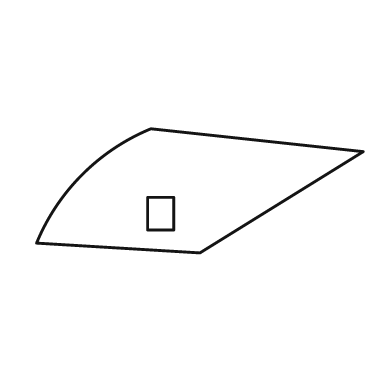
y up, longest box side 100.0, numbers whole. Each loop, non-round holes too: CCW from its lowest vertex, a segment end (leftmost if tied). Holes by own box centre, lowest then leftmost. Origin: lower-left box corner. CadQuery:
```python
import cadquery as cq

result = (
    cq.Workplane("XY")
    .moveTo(50.0, 0.0)
    .lineTo(100.0, 31.0)
    .lineTo(35.0, 38.0)
    .threePointArc((14.0, 24.0), (0.0, 3.0))
    .close()
    .moveTo(34.0, 7.0)
    .lineTo(42.0, 7.0)
    .lineTo(42.0, 17.0)
    .lineTo(34.0, 17.0)
    .close()
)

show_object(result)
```